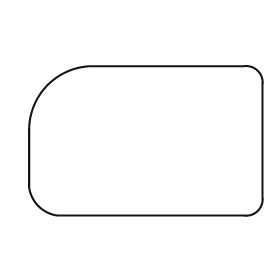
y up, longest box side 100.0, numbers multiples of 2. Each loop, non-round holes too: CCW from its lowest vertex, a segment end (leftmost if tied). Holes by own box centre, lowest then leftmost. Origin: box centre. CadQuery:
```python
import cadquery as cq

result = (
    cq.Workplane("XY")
    .moveTo(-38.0, -32.0)
    .lineTo(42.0, -32.0)
    .threePointArc((48.0, -30.0), (50.0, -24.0))
    .lineTo(50.0, 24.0)
    .threePointArc((48.0, 30.0), (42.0, 32.0))
    .lineTo(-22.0, 32.0)
    .threePointArc((-42.0, 24.0), (-50.0, 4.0))
    .lineTo(-50.0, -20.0)
    .threePointArc((-46.0, -28.0), (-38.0, -32.0))
    .close()
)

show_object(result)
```